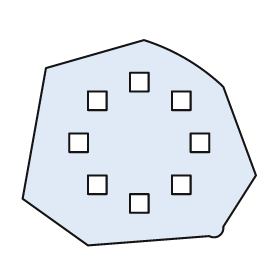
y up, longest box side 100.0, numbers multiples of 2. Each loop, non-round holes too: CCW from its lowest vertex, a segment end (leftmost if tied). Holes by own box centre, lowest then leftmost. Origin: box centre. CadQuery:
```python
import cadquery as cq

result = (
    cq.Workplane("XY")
    .moveTo(-22.0, -44.0)
    .lineTo(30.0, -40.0)
    .threePointArc((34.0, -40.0), (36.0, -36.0))
    .lineTo(50.0, -14.0)
    .lineTo(36.0, 24.0)
    .threePointArc((20.0, 36.0), (2.0, 44.0))
    .lineTo(-40.0, 32.0)
    .lineTo(-50.0, -24.0)
    .close()
    .moveTo(-4.0, -30.0)
    .lineTo(4.0, -30.0)
    .lineTo(4.0, -22.0)
    .lineTo(-4.0, -22.0)
    .close()
    .moveTo(-22.0, -22.0)
    .lineTo(-14.0, -22.0)
    .lineTo(-14.0, -14.0)
    .lineTo(-22.0, -14.0)
    .close()
    .moveTo(14.0, -22.0)
    .lineTo(22.0, -22.0)
    .lineTo(22.0, -14.0)
    .lineTo(14.0, -14.0)
    .close()
    .moveTo(-30.0, -4.0)
    .lineTo(-22.0, -4.0)
    .lineTo(-22.0, 4.0)
    .lineTo(-30.0, 4.0)
    .close()
    .moveTo(22.0, -4.0)
    .lineTo(30.0, -4.0)
    .lineTo(30.0, 4.0)
    .lineTo(22.0, 4.0)
    .close()
    .moveTo(-22.0, 14.0)
    .lineTo(-14.0, 14.0)
    .lineTo(-14.0, 22.0)
    .lineTo(-22.0, 22.0)
    .close()
    .moveTo(14.0, 14.0)
    .lineTo(22.0, 14.0)
    .lineTo(22.0, 22.0)
    .lineTo(14.0, 22.0)
    .close()
    .moveTo(-4.0, 22.0)
    .lineTo(4.0, 22.0)
    .lineTo(4.0, 30.0)
    .lineTo(-4.0, 30.0)
    .close()
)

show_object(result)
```